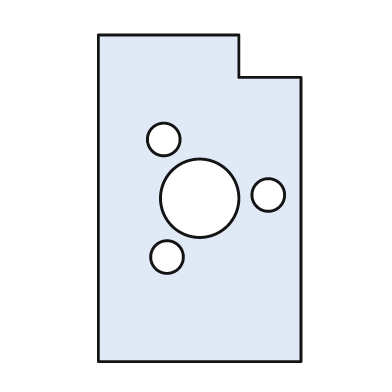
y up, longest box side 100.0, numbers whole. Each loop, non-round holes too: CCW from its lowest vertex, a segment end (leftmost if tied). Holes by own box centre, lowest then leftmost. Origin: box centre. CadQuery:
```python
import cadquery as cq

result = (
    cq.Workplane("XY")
    .moveTo(-31.0, -50.0)
    .lineTo(31.0, -50.0)
    .lineTo(31.0, 37.0)
    .lineTo(12.0, 37.0)
    .lineTo(12.0, 50.0)
    .lineTo(-31.0, 50.0)
    .close()
    .moveTo(-10.0, -18.0)
    .circle(5.0)
    .moveTo(0.0, 0.0)
    .circle(12.0)
    .moveTo(21.0, 1.0)
    .circle(5.0)
    .moveTo(-11.0, 18.0)
    .circle(5.0)
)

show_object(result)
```